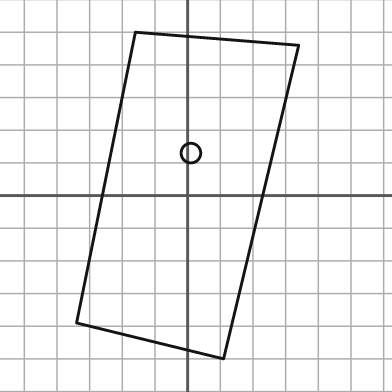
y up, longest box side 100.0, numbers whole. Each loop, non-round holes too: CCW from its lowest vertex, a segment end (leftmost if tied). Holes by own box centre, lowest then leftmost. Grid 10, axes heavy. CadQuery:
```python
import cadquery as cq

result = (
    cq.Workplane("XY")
    .moveTo(11.0, -50.0)
    .lineTo(34.0, 46.0)
    .lineTo(-16.0, 50.0)
    .lineTo(-34.0, -39.0)
    .close()
    .moveTo(1.0, 13.0)
    .circle(3.0)
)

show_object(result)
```